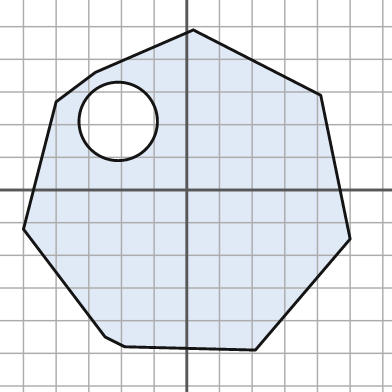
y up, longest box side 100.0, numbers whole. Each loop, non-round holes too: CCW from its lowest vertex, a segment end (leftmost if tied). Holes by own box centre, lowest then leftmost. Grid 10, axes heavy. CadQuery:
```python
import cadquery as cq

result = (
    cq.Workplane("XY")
    .moveTo(21.0, -49.0)
    .lineTo(50.0, -15.0)
    .lineTo(41.0, 29.0)
    .lineTo(2.0, 49.0)
    .lineTo(-28.0, 36.0)
    .lineTo(-40.0, 27.0)
    .lineTo(-50.0, -12.0)
    .lineTo(-25.0, -45.0)
    .lineTo(-19.0, -48.0)
    .close()
    .moveTo(-21.0, 21.0)
    .circle(12.0)
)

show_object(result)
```